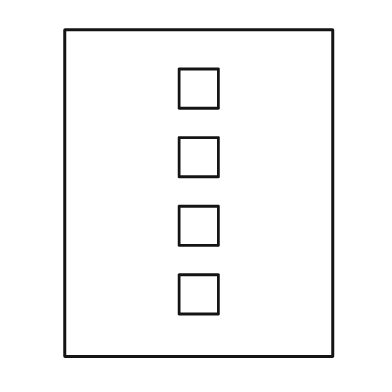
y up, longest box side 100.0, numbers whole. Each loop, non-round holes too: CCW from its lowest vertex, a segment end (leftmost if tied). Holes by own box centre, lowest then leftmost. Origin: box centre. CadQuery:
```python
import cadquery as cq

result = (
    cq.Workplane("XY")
    .moveTo(-41.0, -50.0)
    .lineTo(41.0, -50.0)
    .lineTo(41.0, 50.0)
    .lineTo(-41.0, 50.0)
    .close()
    .moveTo(-6.0, -37.0)
    .lineTo(6.0, -37.0)
    .lineTo(6.0, -25.0)
    .lineTo(-6.0, -25.0)
    .close()
    .moveTo(-6.0, -16.0)
    .lineTo(6.0, -16.0)
    .lineTo(6.0, -4.0)
    .lineTo(-6.0, -4.0)
    .close()
    .moveTo(-6.0, 5.0)
    .lineTo(6.0, 5.0)
    .lineTo(6.0, 17.0)
    .lineTo(-6.0, 17.0)
    .close()
    .moveTo(-6.0, 26.0)
    .lineTo(6.0, 26.0)
    .lineTo(6.0, 38.0)
    .lineTo(-6.0, 38.0)
    .close()
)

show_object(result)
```